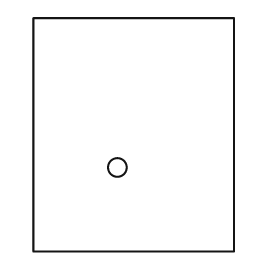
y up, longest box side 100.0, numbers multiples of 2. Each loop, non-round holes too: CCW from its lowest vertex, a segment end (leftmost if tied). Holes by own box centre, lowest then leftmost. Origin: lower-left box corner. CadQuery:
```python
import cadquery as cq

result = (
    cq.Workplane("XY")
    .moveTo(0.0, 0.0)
    .lineTo(86.0, 0.0)
    .lineTo(86.0, 100.0)
    .lineTo(0.0, 100.0)
    .close()
    .moveTo(36.0, 36.0)
    .circle(4.0)
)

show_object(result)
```